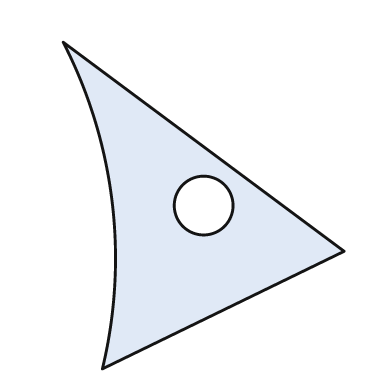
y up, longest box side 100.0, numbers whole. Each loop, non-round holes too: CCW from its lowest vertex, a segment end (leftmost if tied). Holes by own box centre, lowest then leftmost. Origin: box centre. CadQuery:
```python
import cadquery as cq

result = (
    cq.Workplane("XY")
    .moveTo(-31.0, -50.0)
    .lineTo(43.0, -14.0)
    .lineTo(-43.0, 50.0)
    .threePointArc((-28.0, 1.0), (-31.0, -50.0))
    .close()
    .moveTo(0.0, 0.0)
    .circle(9.0)
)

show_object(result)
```